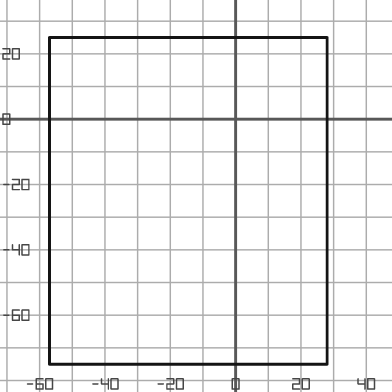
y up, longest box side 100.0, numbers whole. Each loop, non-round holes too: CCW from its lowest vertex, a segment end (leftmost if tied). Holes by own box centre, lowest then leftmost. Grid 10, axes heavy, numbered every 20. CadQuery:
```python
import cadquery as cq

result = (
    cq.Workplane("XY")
    .moveTo(-57.0, -75.0)
    .lineTo(28.0, -75.0)
    .lineTo(28.0, 25.0)
    .lineTo(-57.0, 25.0)
    .close()
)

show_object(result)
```